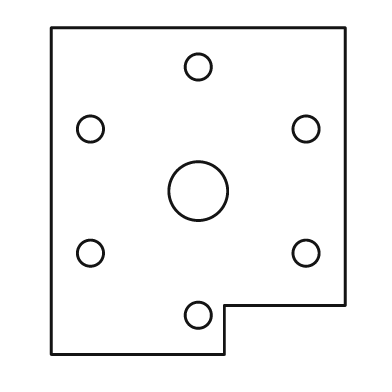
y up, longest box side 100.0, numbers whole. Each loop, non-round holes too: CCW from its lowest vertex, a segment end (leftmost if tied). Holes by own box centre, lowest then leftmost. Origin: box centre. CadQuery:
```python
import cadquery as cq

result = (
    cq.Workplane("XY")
    .moveTo(-45.0, -50.0)
    .lineTo(8.0, -50.0)
    .lineTo(8.0, -35.0)
    .lineTo(45.0, -35.0)
    .lineTo(45.0, 50.0)
    .lineTo(-45.0, 50.0)
    .close()
    .moveTo(0.0, -38.0)
    .circle(4.0)
    .moveTo(-33.0, -19.0)
    .circle(4.0)
    .moveTo(33.0, -19.0)
    .circle(4.0)
    .moveTo(0.0, 0.0)
    .circle(9.0)
    .moveTo(-33.0, 19.0)
    .circle(4.0)
    .moveTo(33.0, 19.0)
    .circle(4.0)
    .moveTo(0.0, 38.0)
    .circle(4.0)
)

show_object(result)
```